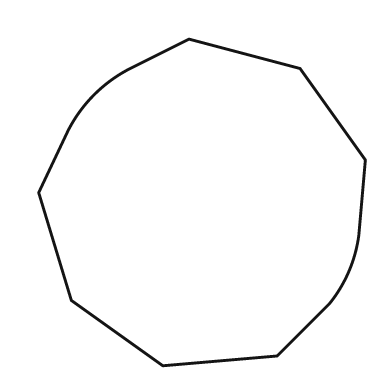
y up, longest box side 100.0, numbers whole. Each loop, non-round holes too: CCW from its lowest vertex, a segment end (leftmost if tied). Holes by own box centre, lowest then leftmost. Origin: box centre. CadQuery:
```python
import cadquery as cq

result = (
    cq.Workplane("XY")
    .moveTo(-12.0, -50.0)
    .lineTo(23.0, -47.0)
    .lineTo(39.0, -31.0)
    .threePointArc((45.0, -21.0), (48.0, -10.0))
    .lineTo(50.0, 13.0)
    .lineTo(30.0, 41.0)
    .lineTo(-4.0, 50.0)
    .lineTo(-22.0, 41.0)
    .threePointArc((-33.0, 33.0), (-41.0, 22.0))
    .lineTo(-50.0, 3.0)
    .lineTo(-40.0, -30.0)
    .close()
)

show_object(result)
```